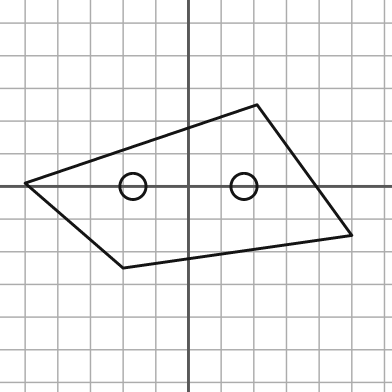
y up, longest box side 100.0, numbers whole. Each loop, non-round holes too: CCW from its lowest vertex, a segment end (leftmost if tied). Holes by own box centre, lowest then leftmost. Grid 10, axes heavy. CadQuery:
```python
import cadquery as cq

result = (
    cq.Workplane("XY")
    .moveTo(-20.0, -25.0)
    .lineTo(50.0, -15.0)
    .lineTo(21.0, 25.0)
    .lineTo(-50.0, 1.0)
    .close()
    .moveTo(-17.0, 0.0)
    .circle(4.0)
    .moveTo(17.0, 0.0)
    .circle(4.0)
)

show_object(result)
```